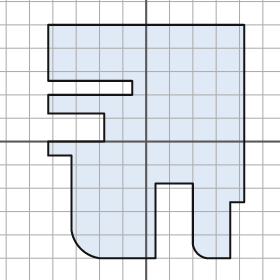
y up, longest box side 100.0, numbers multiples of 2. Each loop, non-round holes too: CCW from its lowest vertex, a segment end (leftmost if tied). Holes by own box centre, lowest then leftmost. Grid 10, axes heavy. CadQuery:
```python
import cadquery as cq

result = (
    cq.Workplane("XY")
    .moveTo(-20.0, -50.0)
    .lineTo(4.0, -50.0)
    .lineTo(4.0, -18.0)
    .lineTo(20.0, -18.0)
    .lineTo(20.0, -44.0)
    .threePointArc((22.0, -48.0), (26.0, -50.0))
    .lineTo(36.0, -50.0)
    .lineTo(36.0, -26.0)
    .lineTo(42.0, -26.0)
    .lineTo(42.0, 50.0)
    .lineTo(-42.0, 50.0)
    .lineTo(-42.0, 26.0)
    .lineTo(-6.0, 26.0)
    .lineTo(-6.0, 20.0)
    .lineTo(-42.0, 20.0)
    .lineTo(-42.0, 12.0)
    .lineTo(-18.0, 12.0)
    .lineTo(-18.0, 0.0)
    .lineTo(-42.0, 0.0)
    .lineTo(-42.0, -6.0)
    .lineTo(-32.0, -6.0)
    .lineTo(-32.0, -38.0)
    .threePointArc((-28.0, -46.0), (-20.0, -50.0))
    .close()
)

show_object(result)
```